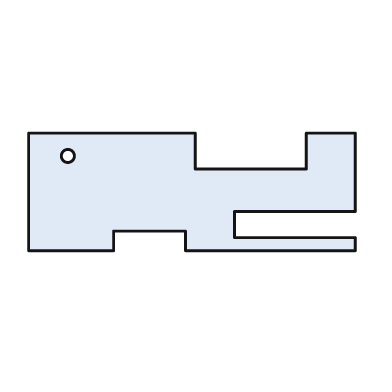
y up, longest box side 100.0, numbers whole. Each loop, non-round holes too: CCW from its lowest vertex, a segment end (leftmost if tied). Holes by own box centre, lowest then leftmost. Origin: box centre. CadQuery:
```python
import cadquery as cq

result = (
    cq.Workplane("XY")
    .moveTo(-50.0, -18.0)
    .lineTo(-24.0, -18.0)
    .lineTo(-24.0, -12.0)
    .lineTo(-2.0, -12.0)
    .lineTo(-2.0, -18.0)
    .lineTo(50.0, -18.0)
    .lineTo(50.0, -14.0)
    .lineTo(13.0, -14.0)
    .lineTo(13.0, -6.0)
    .lineTo(50.0, -6.0)
    .lineTo(50.0, 18.0)
    .lineTo(35.0, 18.0)
    .lineTo(35.0, 7.0)
    .lineTo(1.0, 7.0)
    .lineTo(1.0, 18.0)
    .lineTo(-50.0, 18.0)
    .close()
    .moveTo(-38.0, 11.0)
    .circle(2.0)
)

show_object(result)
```